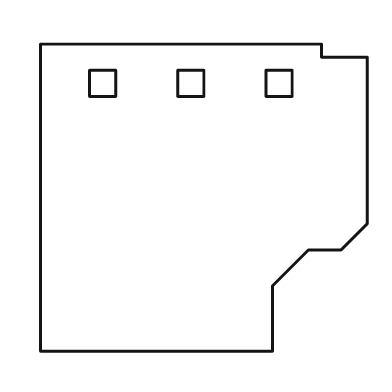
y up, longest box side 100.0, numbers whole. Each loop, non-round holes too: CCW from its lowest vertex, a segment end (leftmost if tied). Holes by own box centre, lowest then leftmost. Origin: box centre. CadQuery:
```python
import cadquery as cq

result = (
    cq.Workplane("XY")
    .moveTo(-50.0, -47.0)
    .lineTo(21.0, -47.0)
    .lineTo(21.0, -27.0)
    .lineTo(32.0, -16.0)
    .lineTo(42.0, -16.0)
    .lineTo(50.0, -8.0)
    .lineTo(50.0, 43.0)
    .lineTo(36.0, 43.0)
    .lineTo(36.0, 47.0)
    .lineTo(-50.0, 47.0)
    .close()
    .moveTo(-35.0, 31.0)
    .lineTo(-27.0, 31.0)
    .lineTo(-27.0, 39.0)
    .lineTo(-35.0, 39.0)
    .close()
    .moveTo(-8.0, 31.0)
    .lineTo(0.0, 31.0)
    .lineTo(0.0, 39.0)
    .lineTo(-8.0, 39.0)
    .close()
    .moveTo(19.0, 31.0)
    .lineTo(27.0, 31.0)
    .lineTo(27.0, 39.0)
    .lineTo(19.0, 39.0)
    .close()
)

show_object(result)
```